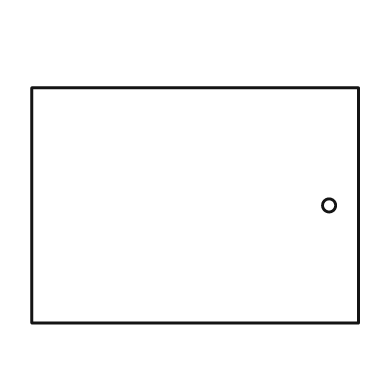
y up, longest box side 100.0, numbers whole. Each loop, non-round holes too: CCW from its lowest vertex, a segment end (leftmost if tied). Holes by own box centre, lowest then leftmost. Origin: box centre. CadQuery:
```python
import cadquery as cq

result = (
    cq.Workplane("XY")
    .moveTo(-50.0, -36.0)
    .lineTo(50.0, -36.0)
    .lineTo(50.0, 36.0)
    .lineTo(-50.0, 36.0)
    .close()
    .moveTo(41.0, 0.0)
    .circle(2.0)
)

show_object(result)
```